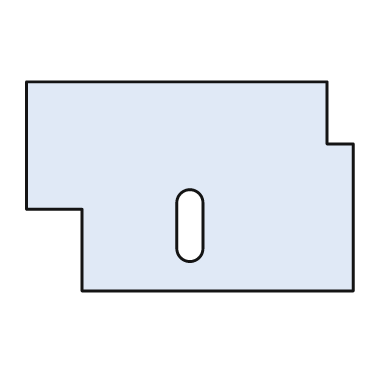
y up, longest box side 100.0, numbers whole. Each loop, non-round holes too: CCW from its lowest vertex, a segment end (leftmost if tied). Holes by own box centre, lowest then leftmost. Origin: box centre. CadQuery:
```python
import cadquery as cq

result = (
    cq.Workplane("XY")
    .moveTo(-33.0, -32.0)
    .lineTo(50.0, -32.0)
    .lineTo(50.0, 13.0)
    .lineTo(42.0, 13.0)
    .lineTo(42.0, 32.0)
    .lineTo(-50.0, 32.0)
    .lineTo(-50.0, -7.0)
    .lineTo(-33.0, -7.0)
    .close()
    .moveTo(-4.0, -19.0)
    .threePointArc((0.0, -23.0), (4.0, -19.0))
    .lineTo(4.0, -5.0)
    .threePointArc((0.0, -1.0), (-4.0, -5.0))
    .close()
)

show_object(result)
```